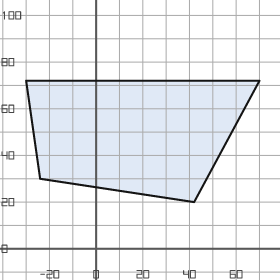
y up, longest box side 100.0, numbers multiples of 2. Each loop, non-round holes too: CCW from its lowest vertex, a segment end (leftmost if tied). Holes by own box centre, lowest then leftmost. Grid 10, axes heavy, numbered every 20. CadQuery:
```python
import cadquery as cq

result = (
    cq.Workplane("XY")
    .moveTo(42.0, 20.0)
    .lineTo(70.0, 72.0)
    .lineTo(-30.0, 72.0)
    .lineTo(-24.0, 30.0)
    .close()
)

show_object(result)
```